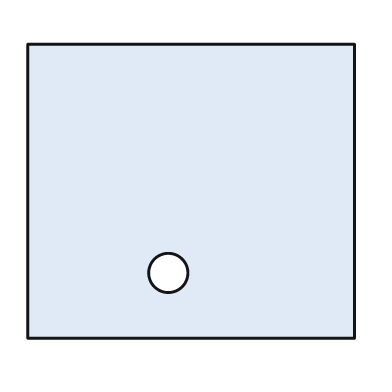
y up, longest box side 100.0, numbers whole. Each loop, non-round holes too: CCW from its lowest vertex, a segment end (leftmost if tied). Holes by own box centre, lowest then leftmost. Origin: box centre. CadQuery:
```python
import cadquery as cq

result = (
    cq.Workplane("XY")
    .moveTo(-50.0, -45.0)
    .lineTo(50.0, -45.0)
    .lineTo(50.0, 45.0)
    .lineTo(-50.0, 45.0)
    .close()
    .moveTo(-7.0, -25.0)
    .circle(6.0)
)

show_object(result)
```